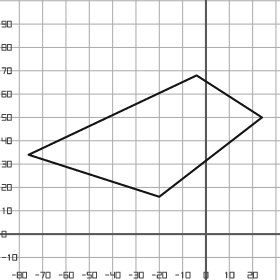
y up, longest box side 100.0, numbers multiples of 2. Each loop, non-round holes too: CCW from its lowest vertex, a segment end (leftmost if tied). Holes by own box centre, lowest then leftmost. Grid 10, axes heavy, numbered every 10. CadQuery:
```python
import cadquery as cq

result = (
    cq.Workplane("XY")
    .moveTo(-20.0, 16.0)
    .lineTo(24.0, 50.0)
    .lineTo(-4.0, 68.0)
    .lineTo(-76.0, 34.0)
    .close()
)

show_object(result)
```